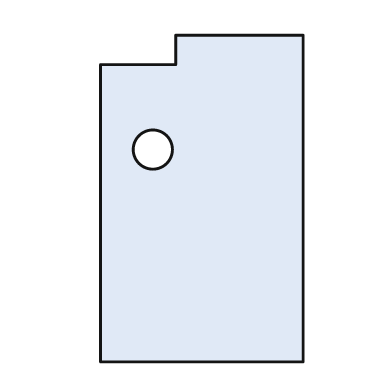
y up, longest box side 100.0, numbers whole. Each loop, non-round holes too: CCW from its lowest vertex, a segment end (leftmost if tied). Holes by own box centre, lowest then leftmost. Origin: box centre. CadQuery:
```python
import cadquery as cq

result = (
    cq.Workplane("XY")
    .moveTo(-31.0, -50.0)
    .lineTo(31.0, -50.0)
    .lineTo(31.0, 50.0)
    .lineTo(-8.0, 50.0)
    .lineTo(-8.0, 41.0)
    .lineTo(-31.0, 41.0)
    .close()
    .moveTo(-15.0, 15.0)
    .circle(6.0)
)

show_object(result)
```